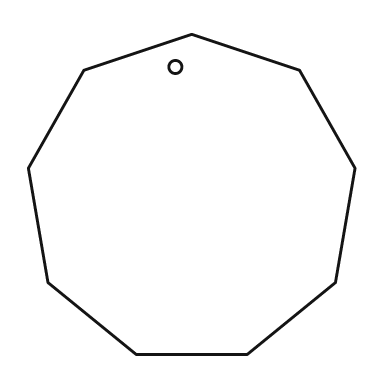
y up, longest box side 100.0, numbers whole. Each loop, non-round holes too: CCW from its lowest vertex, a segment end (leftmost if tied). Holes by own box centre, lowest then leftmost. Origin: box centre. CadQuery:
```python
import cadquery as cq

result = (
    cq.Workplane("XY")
    .moveTo(-17.0, -49.0)
    .lineTo(17.0, -49.0)
    .lineTo(44.0, -27.0)
    .lineTo(50.0, 8.0)
    .lineTo(33.0, 38.0)
    .lineTo(0.0, 49.0)
    .lineTo(-33.0, 38.0)
    .lineTo(-50.0, 8.0)
    .lineTo(-44.0, -27.0)
    .close()
    .moveTo(-5.0, 39.0)
    .circle(2.0)
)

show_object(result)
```